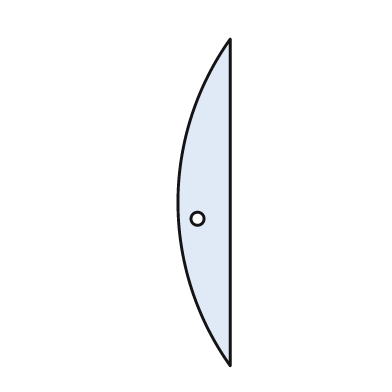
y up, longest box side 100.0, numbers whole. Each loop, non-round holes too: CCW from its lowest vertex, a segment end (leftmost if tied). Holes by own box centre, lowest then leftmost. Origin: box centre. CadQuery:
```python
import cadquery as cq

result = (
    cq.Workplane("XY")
    .moveTo(8.0, -50.0)
    .lineTo(8.0, 50.0)
    .threePointArc((-8.0, 0.0), (8.0, -50.0))
    .close()
    .moveTo(-2.0, -5.0)
    .circle(2.0)
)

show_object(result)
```